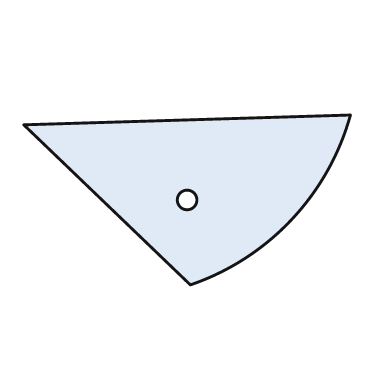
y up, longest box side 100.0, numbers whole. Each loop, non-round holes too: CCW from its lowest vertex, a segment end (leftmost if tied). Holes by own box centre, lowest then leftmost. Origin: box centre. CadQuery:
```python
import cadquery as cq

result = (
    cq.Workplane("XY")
    .moveTo(1.0, -26.0)
    .threePointArc((32.0, -6.0), (50.0, 26.0))
    .lineTo(-50.0, 23.0)
    .close()
    .moveTo(0.0, 0.0)
    .circle(3.0)
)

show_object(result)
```